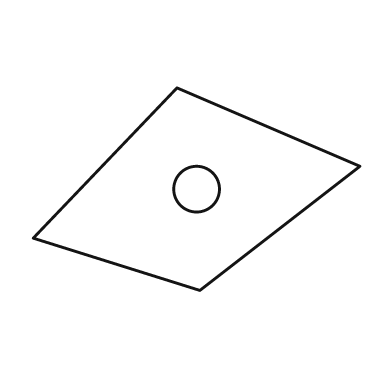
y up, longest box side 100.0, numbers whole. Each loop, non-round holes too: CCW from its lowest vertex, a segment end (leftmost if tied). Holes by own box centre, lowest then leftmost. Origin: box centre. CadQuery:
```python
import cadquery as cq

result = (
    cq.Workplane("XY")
    .moveTo(1.0, -31.0)
    .lineTo(50.0, 7.0)
    .lineTo(-6.0, 31.0)
    .lineTo(-50.0, -15.0)
    .close()
    .moveTo(0.0, 0.0)
    .circle(7.0)
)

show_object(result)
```